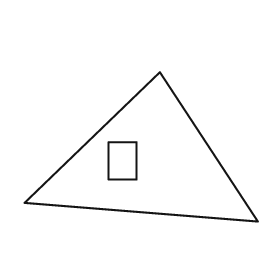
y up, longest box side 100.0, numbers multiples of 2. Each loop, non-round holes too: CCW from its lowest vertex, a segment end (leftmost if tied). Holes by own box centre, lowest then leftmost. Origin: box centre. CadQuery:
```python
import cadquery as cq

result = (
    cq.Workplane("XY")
    .moveTo(50.0, -32.0)
    .lineTo(8.0, 32.0)
    .lineTo(-50.0, -24.0)
    .close()
    .moveTo(-14.0, -14.0)
    .lineTo(-2.0, -14.0)
    .lineTo(-2.0, 2.0)
    .lineTo(-14.0, 2.0)
    .close()
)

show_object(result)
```